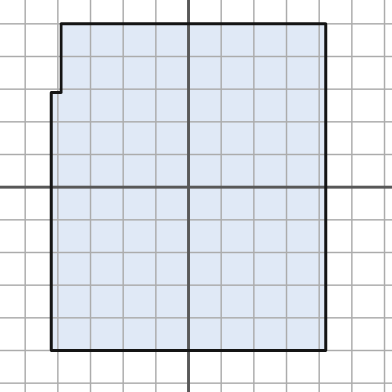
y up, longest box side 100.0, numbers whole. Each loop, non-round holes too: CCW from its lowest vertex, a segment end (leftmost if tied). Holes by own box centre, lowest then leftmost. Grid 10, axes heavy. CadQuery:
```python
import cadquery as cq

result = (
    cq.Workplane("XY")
    .moveTo(-42.0, -50.0)
    .lineTo(42.0, -50.0)
    .lineTo(42.0, 50.0)
    .lineTo(-39.0, 50.0)
    .lineTo(-39.0, 29.0)
    .lineTo(-42.0, 29.0)
    .close()
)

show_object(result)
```